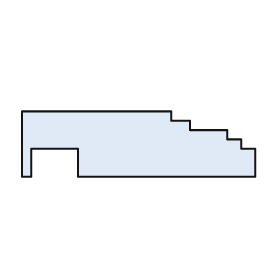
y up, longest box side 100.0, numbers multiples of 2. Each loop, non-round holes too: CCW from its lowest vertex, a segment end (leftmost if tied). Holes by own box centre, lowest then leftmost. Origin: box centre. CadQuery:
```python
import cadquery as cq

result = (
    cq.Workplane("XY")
    .moveTo(-50.0, -14.0)
    .lineTo(-46.0, -14.0)
    .lineTo(-46.0, -2.0)
    .lineTo(-26.0, -2.0)
    .lineTo(-26.0, -14.0)
    .lineTo(50.0, -14.0)
    .lineTo(50.0, -2.0)
    .lineTo(44.0, -2.0)
    .lineTo(44.0, 2.0)
    .lineTo(38.0, 2.0)
    .lineTo(38.0, 6.0)
    .lineTo(22.0, 6.0)
    .lineTo(22.0, 10.0)
    .lineTo(14.0, 10.0)
    .lineTo(14.0, 14.0)
    .lineTo(-50.0, 14.0)
    .close()
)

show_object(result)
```